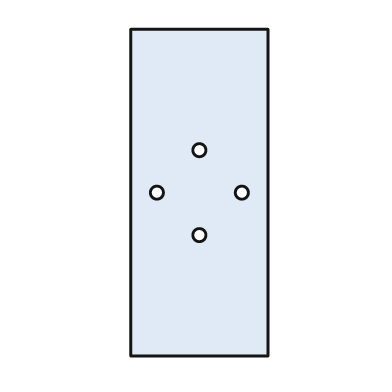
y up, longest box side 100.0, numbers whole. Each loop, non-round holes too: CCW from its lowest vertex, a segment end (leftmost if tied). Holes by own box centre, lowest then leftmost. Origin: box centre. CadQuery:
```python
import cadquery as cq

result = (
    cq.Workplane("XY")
    .moveTo(-21.0, -50.0)
    .lineTo(21.0, -50.0)
    .lineTo(21.0, 50.0)
    .lineTo(-21.0, 50.0)
    .close()
    .moveTo(0.0, -13.0)
    .circle(2.0)
    .moveTo(-13.0, 0.0)
    .circle(2.0)
    .moveTo(13.0, 0.0)
    .circle(2.0)
    .moveTo(0.0, 13.0)
    .circle(2.0)
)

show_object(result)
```